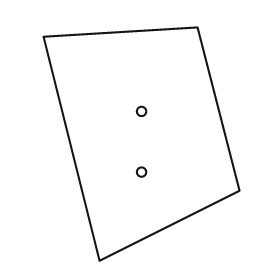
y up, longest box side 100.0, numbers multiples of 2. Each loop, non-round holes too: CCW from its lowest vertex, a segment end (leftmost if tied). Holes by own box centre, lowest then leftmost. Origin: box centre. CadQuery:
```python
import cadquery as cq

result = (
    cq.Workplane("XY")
    .moveTo(-18.0, -50.0)
    .lineTo(42.0, -20.0)
    .lineTo(24.0, 50.0)
    .lineTo(-42.0, 46.0)
    .close()
    .moveTo(0.0, -12.0)
    .circle(2.0)
    .moveTo(0.0, 14.0)
    .circle(2.0)
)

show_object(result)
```